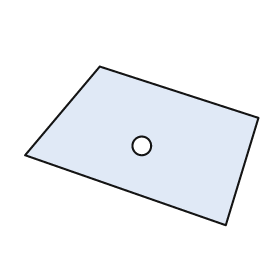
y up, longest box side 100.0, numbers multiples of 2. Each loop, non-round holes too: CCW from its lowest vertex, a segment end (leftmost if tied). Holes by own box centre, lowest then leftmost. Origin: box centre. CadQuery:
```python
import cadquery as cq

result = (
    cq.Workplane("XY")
    .moveTo(36.0, -34.0)
    .lineTo(50.0, 12.0)
    .lineTo(-18.0, 34.0)
    .lineTo(-50.0, -4.0)
    .close()
    .moveTo(0.0, 0.0)
    .circle(4.0)
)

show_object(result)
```